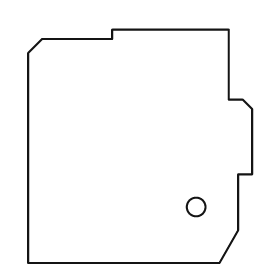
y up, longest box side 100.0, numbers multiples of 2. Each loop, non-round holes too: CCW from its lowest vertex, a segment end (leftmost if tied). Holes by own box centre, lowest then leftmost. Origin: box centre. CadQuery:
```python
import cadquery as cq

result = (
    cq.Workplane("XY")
    .moveTo(-48.0, -50.0)
    .lineTo(34.0, -50.0)
    .lineTo(42.0, -36.0)
    .lineTo(42.0, -12.0)
    .lineTo(48.0, -12.0)
    .lineTo(48.0, 16.0)
    .lineTo(44.0, 20.0)
    .lineTo(38.0, 20.0)
    .lineTo(38.0, 50.0)
    .lineTo(-12.0, 50.0)
    .lineTo(-12.0, 46.0)
    .lineTo(-42.0, 46.0)
    .lineTo(-48.0, 40.0)
    .close()
    .moveTo(24.0, -26.0)
    .circle(4.0)
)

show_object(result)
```